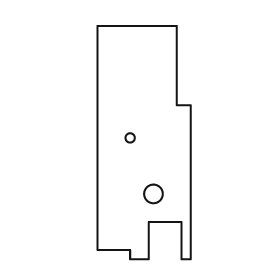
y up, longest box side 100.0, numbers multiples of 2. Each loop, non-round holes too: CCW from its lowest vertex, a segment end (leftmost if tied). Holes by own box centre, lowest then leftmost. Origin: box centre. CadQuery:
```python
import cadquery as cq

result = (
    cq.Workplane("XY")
    .moveTo(-6.0, -50.0)
    .lineTo(2.0, -50.0)
    .lineTo(2.0, -34.0)
    .lineTo(16.0, -34.0)
    .lineTo(16.0, -50.0)
    .lineTo(20.0, -50.0)
    .lineTo(20.0, 16.0)
    .lineTo(14.0, 16.0)
    .lineTo(14.0, 50.0)
    .lineTo(-20.0, 50.0)
    .lineTo(-20.0, -46.0)
    .lineTo(-6.0, -46.0)
    .close()
    .moveTo(4.0, -22.0)
    .circle(4.0)
    .moveTo(-6.0, 2.0)
    .circle(2.0)
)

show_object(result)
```